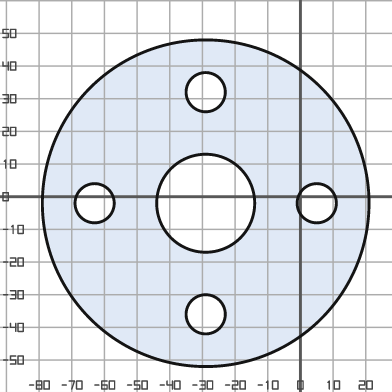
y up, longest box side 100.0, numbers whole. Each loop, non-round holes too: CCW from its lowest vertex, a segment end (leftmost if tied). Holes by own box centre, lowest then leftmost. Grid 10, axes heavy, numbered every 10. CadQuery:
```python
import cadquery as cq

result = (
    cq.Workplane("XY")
    .moveTo(-29.0, -2.0)
    .circle(50.0)
    .moveTo(-29.0, -36.0)
    .circle(6.0)
    .moveTo(-63.0, -2.0)
    .circle(6.0)
    .moveTo(-29.0, -2.0)
    .circle(15.0)
    .moveTo(5.0, -2.0)
    .circle(6.0)
    .moveTo(-29.0, 32.0)
    .circle(6.0)
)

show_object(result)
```